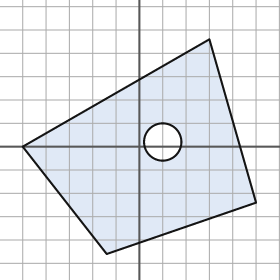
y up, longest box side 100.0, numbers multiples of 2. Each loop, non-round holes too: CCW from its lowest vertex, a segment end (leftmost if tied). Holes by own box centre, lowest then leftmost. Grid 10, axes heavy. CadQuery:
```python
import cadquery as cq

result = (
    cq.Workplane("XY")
    .moveTo(-14.0, -46.0)
    .lineTo(50.0, -24.0)
    .lineTo(30.0, 46.0)
    .lineTo(-50.0, 0.0)
    .close()
    .moveTo(10.0, 2.0)
    .circle(8.0)
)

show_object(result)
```